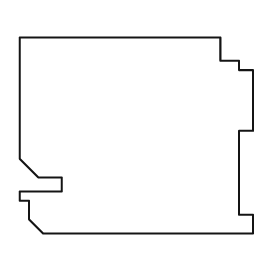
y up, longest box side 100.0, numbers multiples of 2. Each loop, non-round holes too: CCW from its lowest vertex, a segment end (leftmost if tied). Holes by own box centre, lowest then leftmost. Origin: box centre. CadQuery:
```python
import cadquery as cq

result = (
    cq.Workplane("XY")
    .moveTo(-40.0, -42.0)
    .lineTo(50.0, -42.0)
    .lineTo(50.0, -34.0)
    .lineTo(44.0, -34.0)
    .lineTo(44.0, 2.0)
    .lineTo(50.0, 2.0)
    .lineTo(50.0, 28.0)
    .lineTo(44.0, 28.0)
    .lineTo(44.0, 32.0)
    .lineTo(36.0, 32.0)
    .lineTo(36.0, 42.0)
    .lineTo(-50.0, 42.0)
    .lineTo(-50.0, -10.0)
    .lineTo(-42.0, -18.0)
    .lineTo(-32.0, -18.0)
    .lineTo(-32.0, -24.0)
    .lineTo(-50.0, -24.0)
    .lineTo(-50.0, -28.0)
    .lineTo(-46.0, -28.0)
    .lineTo(-46.0, -36.0)
    .close()
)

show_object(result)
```